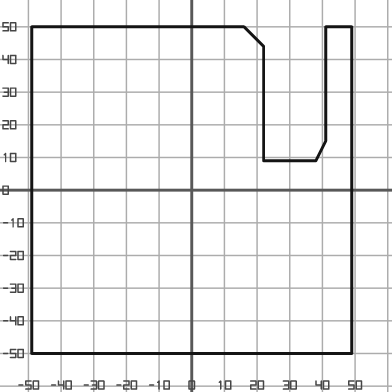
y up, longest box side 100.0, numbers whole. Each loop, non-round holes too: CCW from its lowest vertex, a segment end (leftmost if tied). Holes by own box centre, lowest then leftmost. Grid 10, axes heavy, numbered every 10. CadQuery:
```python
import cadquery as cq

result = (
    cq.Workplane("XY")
    .moveTo(-49.0, -50.0)
    .lineTo(49.0, -50.0)
    .lineTo(49.0, 50.0)
    .lineTo(41.0, 50.0)
    .lineTo(41.0, 15.0)
    .lineTo(38.0, 9.0)
    .lineTo(22.0, 9.0)
    .lineTo(22.0, 44.0)
    .lineTo(16.0, 50.0)
    .lineTo(-49.0, 50.0)
    .close()
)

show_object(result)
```